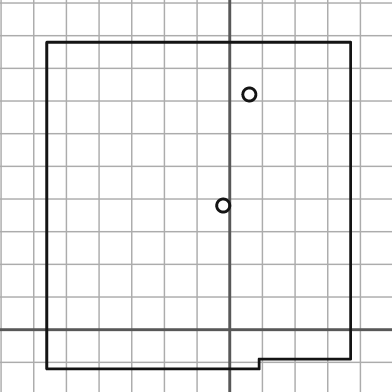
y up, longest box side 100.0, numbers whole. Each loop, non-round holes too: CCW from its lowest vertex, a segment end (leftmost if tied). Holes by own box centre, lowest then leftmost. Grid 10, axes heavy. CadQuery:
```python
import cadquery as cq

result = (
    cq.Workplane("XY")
    .moveTo(-56.0, -12.0)
    .lineTo(9.0, -12.0)
    .lineTo(9.0, -9.0)
    .lineTo(37.0, -9.0)
    .lineTo(37.0, 88.0)
    .lineTo(-56.0, 88.0)
    .close()
    .moveTo(-2.0, 38.0)
    .circle(2.0)
    .moveTo(6.0, 72.0)
    .circle(2.0)
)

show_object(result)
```